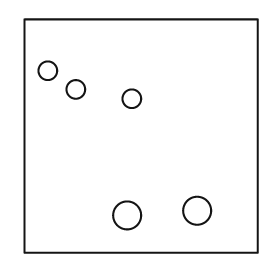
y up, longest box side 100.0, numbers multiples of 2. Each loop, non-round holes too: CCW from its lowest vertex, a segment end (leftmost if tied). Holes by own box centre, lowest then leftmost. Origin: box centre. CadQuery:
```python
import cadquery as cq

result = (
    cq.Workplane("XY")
    .moveTo(-50.0, -50.0)
    .lineTo(50.0, -50.0)
    .lineTo(50.0, 50.0)
    .lineTo(-50.0, 50.0)
    .close()
    .moveTo(-6.0, -34.0)
    .circle(6.0)
    .moveTo(24.0, -32.0)
    .circle(6.0)
    .moveTo(-4.0, 16.0)
    .circle(4.0)
    .moveTo(-28.0, 20.0)
    .circle(4.0)
    .moveTo(-40.0, 28.0)
    .circle(4.0)
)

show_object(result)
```